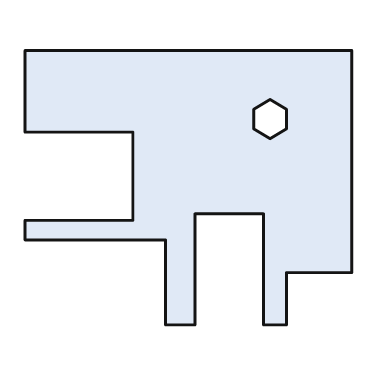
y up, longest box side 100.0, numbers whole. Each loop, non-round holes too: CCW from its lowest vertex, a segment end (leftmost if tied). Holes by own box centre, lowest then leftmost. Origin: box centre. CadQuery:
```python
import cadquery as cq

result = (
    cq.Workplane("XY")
    .moveTo(-7.0, -42.0)
    .lineTo(2.0, -42.0)
    .lineTo(2.0, -8.0)
    .lineTo(23.0, -8.0)
    .lineTo(23.0, -42.0)
    .lineTo(30.0, -42.0)
    .lineTo(30.0, -26.0)
    .lineTo(50.0, -26.0)
    .lineTo(50.0, 42.0)
    .lineTo(-50.0, 42.0)
    .lineTo(-50.0, 17.0)
    .lineTo(-17.0, 17.0)
    .lineTo(-17.0, -10.0)
    .lineTo(-50.0, -10.0)
    .lineTo(-50.0, -16.0)
    .lineTo(-7.0, -16.0)
    .close()
    .moveTo(25.0, 15.0)
    .lineTo(30.0, 18.0)
    .lineTo(30.0, 24.0)
    .lineTo(25.0, 27.0)
    .lineTo(20.0, 24.0)
    .lineTo(20.0, 18.0)
    .close()
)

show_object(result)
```